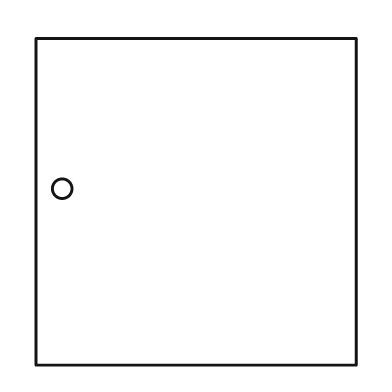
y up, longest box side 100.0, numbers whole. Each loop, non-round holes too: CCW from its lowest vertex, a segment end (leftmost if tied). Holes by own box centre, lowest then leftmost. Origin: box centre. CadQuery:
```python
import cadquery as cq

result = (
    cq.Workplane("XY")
    .moveTo(-49.0, -50.0)
    .lineTo(49.0, -50.0)
    .lineTo(49.0, 50.0)
    .lineTo(-49.0, 50.0)
    .close()
    .moveTo(-41.0, 4.0)
    .circle(3.0)
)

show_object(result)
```